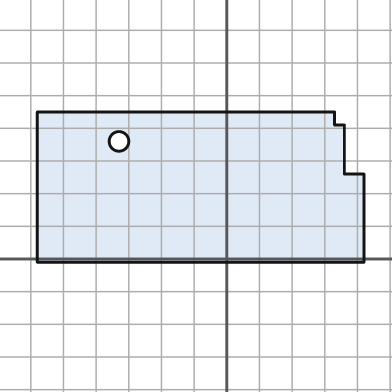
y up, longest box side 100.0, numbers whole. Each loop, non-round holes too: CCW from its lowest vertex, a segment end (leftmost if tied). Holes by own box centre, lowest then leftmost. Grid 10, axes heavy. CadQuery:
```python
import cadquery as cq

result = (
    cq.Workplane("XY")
    .moveTo(-58.0, -1.0)
    .lineTo(42.0, -1.0)
    .lineTo(42.0, 26.0)
    .lineTo(36.0, 26.0)
    .lineTo(36.0, 41.0)
    .lineTo(33.0, 41.0)
    .lineTo(33.0, 45.0)
    .lineTo(-58.0, 45.0)
    .close()
    .moveTo(-33.0, 36.0)
    .circle(3.0)
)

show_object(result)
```